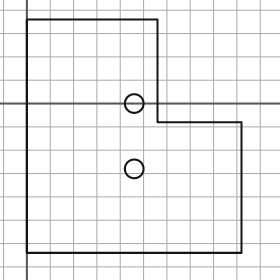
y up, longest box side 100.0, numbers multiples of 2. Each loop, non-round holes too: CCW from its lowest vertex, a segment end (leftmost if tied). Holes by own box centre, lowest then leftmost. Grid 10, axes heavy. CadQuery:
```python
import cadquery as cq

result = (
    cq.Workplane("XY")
    .moveTo(0.0, -64.0)
    .lineTo(92.0, -64.0)
    .lineTo(92.0, -8.0)
    .lineTo(56.0, -8.0)
    .lineTo(56.0, 36.0)
    .lineTo(0.0, 36.0)
    .close()
    .moveTo(46.0, -28.0)
    .circle(4.0)
    .moveTo(46.0, 0.0)
    .circle(4.0)
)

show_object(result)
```